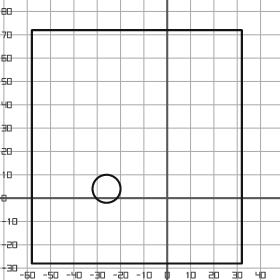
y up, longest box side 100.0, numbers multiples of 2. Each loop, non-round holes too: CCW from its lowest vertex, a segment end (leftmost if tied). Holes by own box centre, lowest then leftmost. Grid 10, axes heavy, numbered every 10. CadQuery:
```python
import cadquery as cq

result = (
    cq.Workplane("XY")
    .moveTo(-58.0, -28.0)
    .lineTo(32.0, -28.0)
    .lineTo(32.0, 72.0)
    .lineTo(-58.0, 72.0)
    .close()
    .moveTo(-26.0, 4.0)
    .circle(6.0)
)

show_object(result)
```